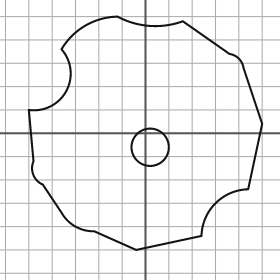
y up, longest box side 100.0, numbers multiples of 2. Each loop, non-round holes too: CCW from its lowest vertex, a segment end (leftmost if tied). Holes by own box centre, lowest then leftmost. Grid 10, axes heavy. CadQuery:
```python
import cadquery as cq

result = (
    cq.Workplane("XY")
    .moveTo(-4.0, -50.0)
    .lineTo(24.0, -44.0)
    .threePointArc((30.0, -30.0), (44.0, -24.0))
    .lineTo(50.0, 4.0)
    .lineTo(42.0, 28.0)
    .threePointArc((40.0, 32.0), (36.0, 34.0))
    .lineTo(16.0, 48.0)
    .threePointArc((2.0, 46.0), (-12.0, 50.0))
    .threePointArc((-26.0, 46.0), (-36.0, 36.0))
    .threePointArc((-34.0, 18.0), (-50.0, 10.0))
    .lineTo(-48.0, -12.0)
    .threePointArc((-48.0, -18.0), (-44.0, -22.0))
    .lineTo(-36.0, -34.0)
    .threePointArc((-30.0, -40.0), (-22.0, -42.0))
    .close()
    .moveTo(2.0, -6.0)
    .circle(8.0)
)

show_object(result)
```